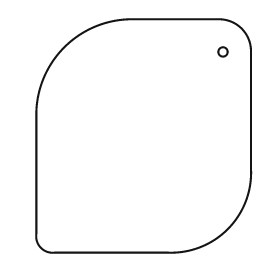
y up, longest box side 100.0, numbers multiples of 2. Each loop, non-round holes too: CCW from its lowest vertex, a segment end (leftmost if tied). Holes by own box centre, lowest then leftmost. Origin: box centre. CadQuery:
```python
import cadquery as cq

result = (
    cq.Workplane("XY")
    .moveTo(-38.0, -50.0)
    .lineTo(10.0, -50.0)
    .threePointArc((36.0, -40.0), (46.0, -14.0))
    .lineTo(46.0, 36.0)
    .threePointArc((42.0, 46.0), (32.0, 50.0))
    .lineTo(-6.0, 50.0)
    .threePointArc((-34.0, 38.0), (-46.0, 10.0))
    .lineTo(-46.0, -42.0)
    .threePointArc((-44.0, -48.0), (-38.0, -50.0))
    .close()
    .moveTo(34.0, 36.0)
    .circle(2.0)
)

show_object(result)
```